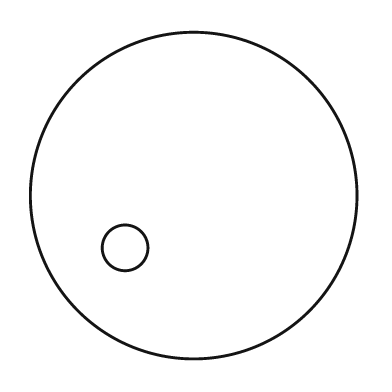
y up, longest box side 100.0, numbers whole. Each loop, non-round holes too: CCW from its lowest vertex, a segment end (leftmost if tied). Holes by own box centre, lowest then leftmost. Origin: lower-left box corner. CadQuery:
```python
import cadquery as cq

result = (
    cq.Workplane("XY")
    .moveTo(50.0, 50.0)
    .circle(50.0)
    .moveTo(29.0, 34.0)
    .circle(7.0)
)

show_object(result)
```